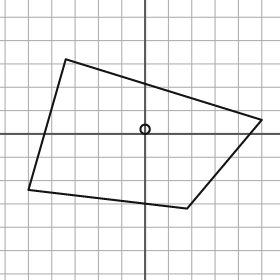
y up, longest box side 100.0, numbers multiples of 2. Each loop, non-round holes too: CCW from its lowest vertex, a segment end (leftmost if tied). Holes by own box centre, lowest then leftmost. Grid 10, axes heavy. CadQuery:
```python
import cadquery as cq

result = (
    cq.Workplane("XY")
    .moveTo(18.0, -32.0)
    .lineTo(50.0, 6.0)
    .lineTo(-34.0, 32.0)
    .lineTo(-50.0, -24.0)
    .close()
    .moveTo(0.0, 2.0)
    .circle(2.0)
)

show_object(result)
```